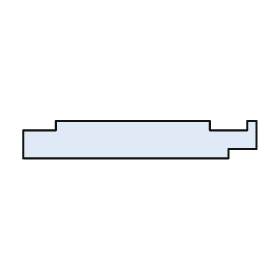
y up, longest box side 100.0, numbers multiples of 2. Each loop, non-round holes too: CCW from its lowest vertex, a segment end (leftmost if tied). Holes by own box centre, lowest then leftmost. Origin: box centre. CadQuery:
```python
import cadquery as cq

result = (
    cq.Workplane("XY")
    .moveTo(-50.0, -8.0)
    .lineTo(38.0, -8.0)
    .lineTo(38.0, -4.0)
    .lineTo(50.0, -4.0)
    .lineTo(50.0, 8.0)
    .lineTo(46.0, 8.0)
    .lineTo(46.0, 4.0)
    .lineTo(30.0, 4.0)
    .lineTo(30.0, 8.0)
    .lineTo(-36.0, 8.0)
    .lineTo(-36.0, 4.0)
    .lineTo(-50.0, 4.0)
    .close()
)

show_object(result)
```